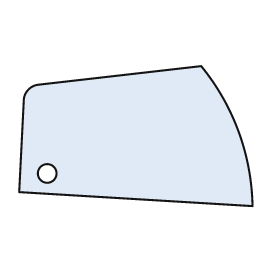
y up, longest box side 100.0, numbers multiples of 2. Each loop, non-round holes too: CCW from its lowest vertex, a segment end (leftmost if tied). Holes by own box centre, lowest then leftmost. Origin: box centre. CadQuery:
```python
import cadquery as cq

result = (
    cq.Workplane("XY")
    .moveTo(50.0, -30.0)
    .threePointArc((44.0, 2.0), (28.0, 30.0))
    .lineTo(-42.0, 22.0)
    .threePointArc((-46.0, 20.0), (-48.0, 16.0))
    .lineTo(-50.0, -24.0)
    .close()
    .moveTo(-38.0, -16.0)
    .circle(4.0)
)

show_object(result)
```